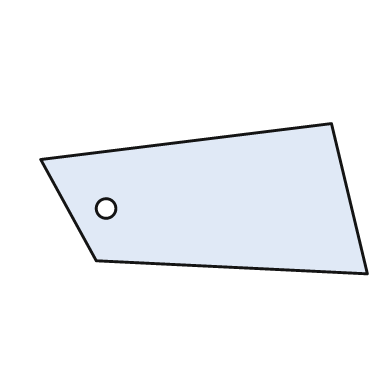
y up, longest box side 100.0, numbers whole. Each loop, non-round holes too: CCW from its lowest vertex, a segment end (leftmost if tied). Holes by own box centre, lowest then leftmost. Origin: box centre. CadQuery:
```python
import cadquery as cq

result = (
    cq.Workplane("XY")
    .moveTo(50.0, -23.0)
    .lineTo(39.0, 23.0)
    .lineTo(-50.0, 12.0)
    .lineTo(-33.0, -19.0)
    .close()
    .moveTo(-30.0, -3.0)
    .circle(3.0)
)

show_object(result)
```